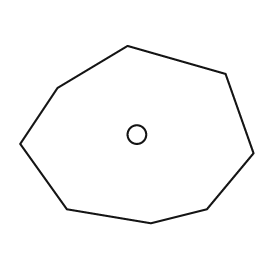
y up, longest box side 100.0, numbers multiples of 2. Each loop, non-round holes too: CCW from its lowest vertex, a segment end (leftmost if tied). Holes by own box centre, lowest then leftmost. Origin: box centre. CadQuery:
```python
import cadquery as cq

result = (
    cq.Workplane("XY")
    .moveTo(6.0, -38.0)
    .lineTo(30.0, -32.0)
    .lineTo(50.0, -8.0)
    .lineTo(38.0, 26.0)
    .lineTo(-4.0, 38.0)
    .lineTo(-34.0, 20.0)
    .lineTo(-50.0, -4.0)
    .lineTo(-30.0, -32.0)
    .close()
    .moveTo(0.0, 0.0)
    .circle(4.0)
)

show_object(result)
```